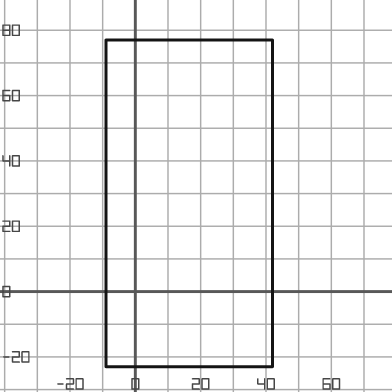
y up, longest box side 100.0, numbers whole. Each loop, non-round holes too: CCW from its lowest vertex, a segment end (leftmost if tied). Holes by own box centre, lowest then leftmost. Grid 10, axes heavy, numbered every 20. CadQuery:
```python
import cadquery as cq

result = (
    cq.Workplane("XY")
    .moveTo(-9.0, -23.0)
    .lineTo(42.0, -23.0)
    .lineTo(42.0, 77.0)
    .lineTo(-9.0, 77.0)
    .close()
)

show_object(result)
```